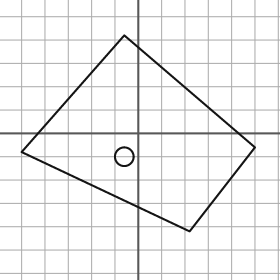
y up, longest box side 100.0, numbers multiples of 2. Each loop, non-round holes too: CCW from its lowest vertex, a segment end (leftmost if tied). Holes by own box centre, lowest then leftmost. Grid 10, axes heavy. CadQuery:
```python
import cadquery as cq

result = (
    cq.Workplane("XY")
    .moveTo(22.0, -42.0)
    .lineTo(50.0, -6.0)
    .lineTo(-6.0, 42.0)
    .lineTo(-50.0, -8.0)
    .close()
    .moveTo(-6.0, -10.0)
    .circle(4.0)
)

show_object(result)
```